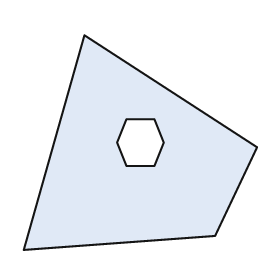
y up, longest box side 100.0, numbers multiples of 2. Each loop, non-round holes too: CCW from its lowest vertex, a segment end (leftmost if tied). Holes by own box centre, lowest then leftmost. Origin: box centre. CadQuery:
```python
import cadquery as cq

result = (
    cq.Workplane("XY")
    .moveTo(-50.0, -46.0)
    .lineTo(32.0, -40.0)
    .lineTo(50.0, -2.0)
    .lineTo(-24.0, 46.0)
    .close()
    .moveTo(-6.0, -10.0)
    .lineTo(6.0, -10.0)
    .lineTo(10.0, 0.0)
    .lineTo(6.0, 10.0)
    .lineTo(-6.0, 10.0)
    .lineTo(-10.0, 0.0)
    .close()
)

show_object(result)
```